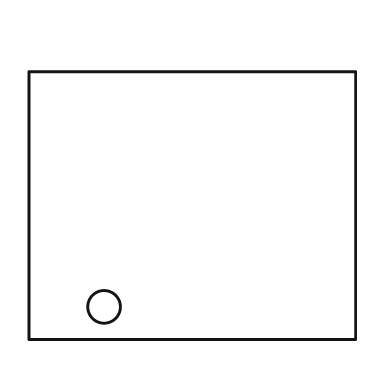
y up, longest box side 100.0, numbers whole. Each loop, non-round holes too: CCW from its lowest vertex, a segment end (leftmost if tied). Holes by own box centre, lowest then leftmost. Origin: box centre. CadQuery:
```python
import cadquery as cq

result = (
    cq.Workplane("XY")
    .moveTo(-50.0, -41.0)
    .lineTo(50.0, -41.0)
    .lineTo(50.0, 41.0)
    .lineTo(-50.0, 41.0)
    .close()
    .moveTo(-27.0, -31.0)
    .circle(5.0)
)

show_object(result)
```